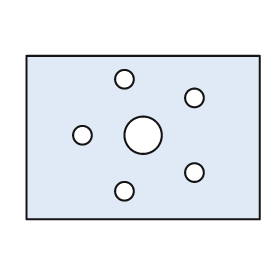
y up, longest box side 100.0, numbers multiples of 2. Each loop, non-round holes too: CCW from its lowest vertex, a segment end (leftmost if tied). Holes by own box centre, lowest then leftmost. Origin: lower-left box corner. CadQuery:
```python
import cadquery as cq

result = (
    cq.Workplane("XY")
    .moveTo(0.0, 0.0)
    .lineTo(100.0, 0.0)
    .lineTo(100.0, 70.0)
    .lineTo(0.0, 70.0)
    .close()
    .moveTo(42.0, 12.0)
    .circle(4.0)
    .moveTo(72.0, 20.0)
    .circle(4.0)
    .moveTo(24.0, 36.0)
    .circle(4.0)
    .moveTo(50.0, 36.0)
    .circle(8.0)
    .moveTo(72.0, 52.0)
    .circle(4.0)
    .moveTo(42.0, 60.0)
    .circle(4.0)
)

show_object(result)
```